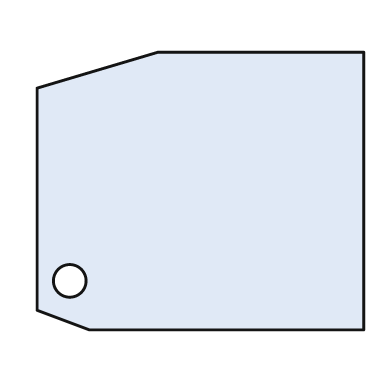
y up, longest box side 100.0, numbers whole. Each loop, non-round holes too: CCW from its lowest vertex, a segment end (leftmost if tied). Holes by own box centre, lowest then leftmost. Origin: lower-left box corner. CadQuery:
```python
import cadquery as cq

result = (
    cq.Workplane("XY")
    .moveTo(16.0, 0.0)
    .lineTo(100.0, 0.0)
    .lineTo(100.0, 85.0)
    .lineTo(37.0, 85.0)
    .lineTo(0.0, 74.0)
    .lineTo(0.0, 6.0)
    .close()
    .moveTo(10.0, 15.0)
    .circle(5.0)
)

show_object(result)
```